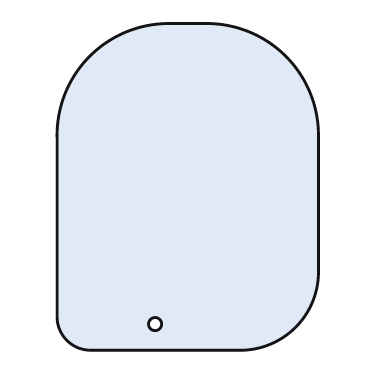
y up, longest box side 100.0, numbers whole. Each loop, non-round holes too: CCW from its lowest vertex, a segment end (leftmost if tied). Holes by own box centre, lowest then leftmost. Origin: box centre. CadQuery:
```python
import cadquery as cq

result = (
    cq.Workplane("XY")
    .moveTo(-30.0, -50.0)
    .lineTo(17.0, -50.0)
    .threePointArc((33.0, -43.0), (40.0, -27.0))
    .lineTo(40.0, 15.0)
    .threePointArc((30.0, 40.0), (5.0, 50.0))
    .lineTo(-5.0, 50.0)
    .threePointArc((-30.0, 40.0), (-40.0, 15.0))
    .lineTo(-40.0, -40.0)
    .threePointArc((-37.0, -47.0), (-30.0, -50.0))
    .close()
    .moveTo(-10.0, -42.0)
    .circle(2.0)
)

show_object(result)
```